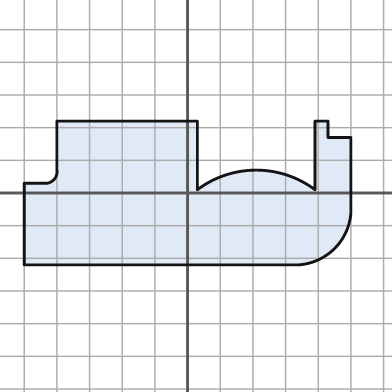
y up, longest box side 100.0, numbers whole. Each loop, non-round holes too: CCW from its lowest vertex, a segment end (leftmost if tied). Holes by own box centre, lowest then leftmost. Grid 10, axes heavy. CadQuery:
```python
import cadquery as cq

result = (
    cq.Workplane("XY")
    .moveTo(-50.0, -22.0)
    .lineTo(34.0, -22.0)
    .threePointArc((45.0, -17.0), (50.0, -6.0))
    .lineTo(50.0, 17.0)
    .lineTo(43.0, 17.0)
    .lineTo(43.0, 22.0)
    .lineTo(39.0, 22.0)
    .lineTo(39.0, 1.0)
    .threePointArc((21.0, 7.0), (3.0, 1.0))
    .lineTo(3.0, 22.0)
    .lineTo(-40.0, 22.0)
    .lineTo(-40.0, 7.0)
    .threePointArc((-41.0, 4.0), (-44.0, 3.0))
    .lineTo(-50.0, 3.0)
    .close()
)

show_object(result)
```